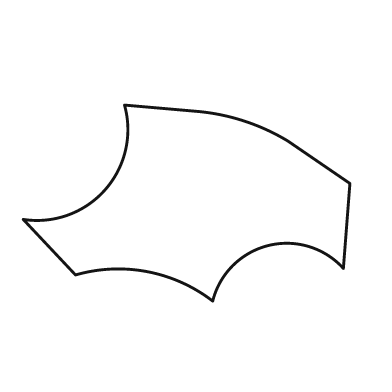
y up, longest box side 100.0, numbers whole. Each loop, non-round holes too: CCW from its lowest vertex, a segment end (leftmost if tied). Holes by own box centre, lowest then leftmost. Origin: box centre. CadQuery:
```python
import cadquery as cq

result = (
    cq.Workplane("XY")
    .moveTo(8.0, -30.0)
    .threePointArc((25.0, -13.0), (48.0, -20.0))
    .lineTo(50.0, 6.0)
    .lineTo(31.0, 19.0)
    .threePointArc((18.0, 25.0), (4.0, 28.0))
    .lineTo(-19.0, 30.0)
    .threePointArc((-25.0, 4.0), (-50.0, -5.0))
    .lineTo(-34.0, -22.0)
    .threePointArc((-12.0, -21.0), (8.0, -30.0))
    .close()
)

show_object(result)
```